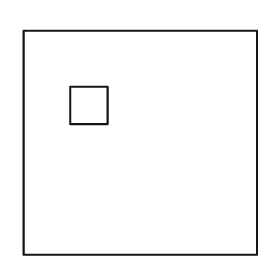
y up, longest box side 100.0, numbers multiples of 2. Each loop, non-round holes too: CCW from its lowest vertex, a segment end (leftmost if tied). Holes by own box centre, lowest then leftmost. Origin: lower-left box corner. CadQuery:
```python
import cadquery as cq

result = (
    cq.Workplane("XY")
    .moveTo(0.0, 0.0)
    .lineTo(100.0, 0.0)
    .lineTo(100.0, 96.0)
    .lineTo(0.0, 96.0)
    .close()
    .moveTo(20.0, 56.0)
    .lineTo(36.0, 56.0)
    .lineTo(36.0, 72.0)
    .lineTo(20.0, 72.0)
    .close()
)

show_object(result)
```